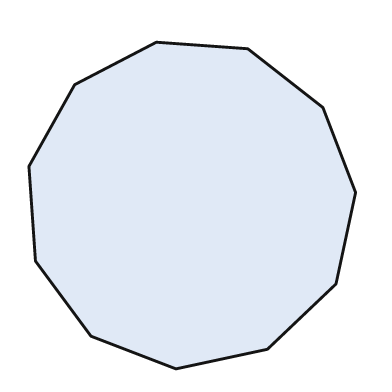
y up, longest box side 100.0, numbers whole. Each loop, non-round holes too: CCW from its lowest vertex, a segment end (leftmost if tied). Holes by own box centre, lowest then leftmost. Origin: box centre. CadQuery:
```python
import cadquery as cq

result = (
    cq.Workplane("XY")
    .moveTo(-5.0, -50.0)
    .lineTo(23.0, -44.0)
    .lineTo(44.0, -24.0)
    .lineTo(50.0, 4.0)
    .lineTo(40.0, 30.0)
    .lineTo(17.0, 48.0)
    .lineTo(-11.0, 50.0)
    .lineTo(-36.0, 37.0)
    .lineTo(-50.0, 12.0)
    .lineTo(-48.0, -17.0)
    .lineTo(-31.0, -40.0)
    .close()
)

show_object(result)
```